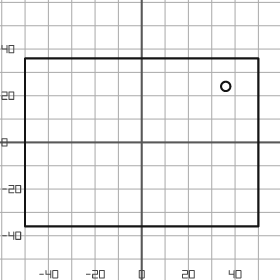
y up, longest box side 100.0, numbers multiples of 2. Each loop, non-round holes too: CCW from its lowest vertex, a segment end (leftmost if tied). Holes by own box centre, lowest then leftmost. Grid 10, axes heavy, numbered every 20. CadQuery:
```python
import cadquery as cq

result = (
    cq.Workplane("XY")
    .moveTo(-50.0, -36.0)
    .lineTo(50.0, -36.0)
    .lineTo(50.0, 36.0)
    .lineTo(-50.0, 36.0)
    .close()
    .moveTo(36.0, 24.0)
    .circle(2.0)
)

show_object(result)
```